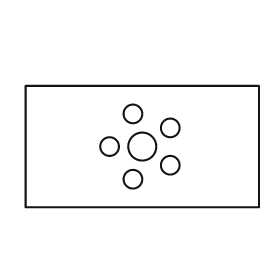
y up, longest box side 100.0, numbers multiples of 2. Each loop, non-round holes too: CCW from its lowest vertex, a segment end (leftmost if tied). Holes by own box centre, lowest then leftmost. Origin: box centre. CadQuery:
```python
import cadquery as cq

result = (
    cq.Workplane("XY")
    .moveTo(-50.0, -26.0)
    .lineTo(50.0, -26.0)
    .lineTo(50.0, 26.0)
    .lineTo(-50.0, 26.0)
    .close()
    .moveTo(-4.0, -14.0)
    .circle(4.0)
    .moveTo(12.0, -8.0)
    .circle(4.0)
    .moveTo(-14.0, 0.0)
    .circle(4.0)
    .moveTo(0.0, 0.0)
    .circle(6.0)
    .moveTo(12.0, 8.0)
    .circle(4.0)
    .moveTo(-4.0, 14.0)
    .circle(4.0)
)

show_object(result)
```